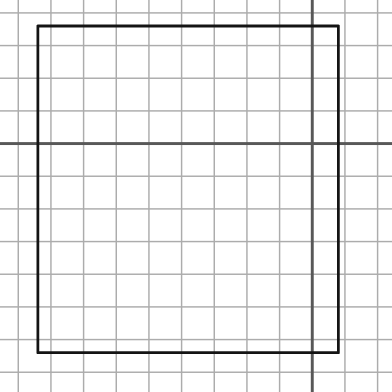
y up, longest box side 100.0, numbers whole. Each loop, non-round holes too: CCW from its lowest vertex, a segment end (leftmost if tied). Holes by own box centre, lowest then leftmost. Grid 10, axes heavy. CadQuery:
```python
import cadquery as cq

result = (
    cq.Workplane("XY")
    .moveTo(-84.0, -64.0)
    .lineTo(8.0, -64.0)
    .lineTo(8.0, 36.0)
    .lineTo(-84.0, 36.0)
    .close()
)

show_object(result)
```